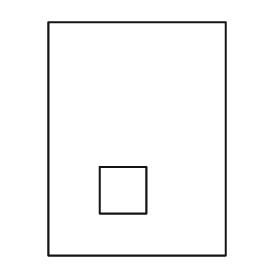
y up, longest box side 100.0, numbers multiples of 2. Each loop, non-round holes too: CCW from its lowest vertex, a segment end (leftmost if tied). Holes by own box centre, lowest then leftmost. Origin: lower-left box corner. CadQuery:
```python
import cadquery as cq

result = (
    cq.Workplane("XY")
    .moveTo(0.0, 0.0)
    .lineTo(76.0, 0.0)
    .lineTo(76.0, 100.0)
    .lineTo(0.0, 100.0)
    .close()
    .moveTo(22.0, 18.0)
    .lineTo(42.0, 18.0)
    .lineTo(42.0, 38.0)
    .lineTo(22.0, 38.0)
    .close()
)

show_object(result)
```